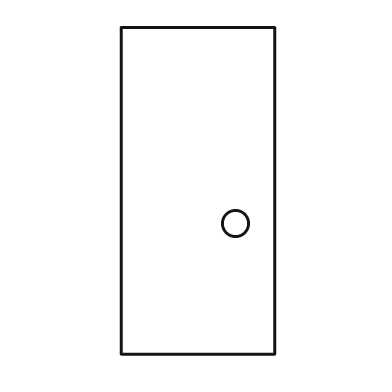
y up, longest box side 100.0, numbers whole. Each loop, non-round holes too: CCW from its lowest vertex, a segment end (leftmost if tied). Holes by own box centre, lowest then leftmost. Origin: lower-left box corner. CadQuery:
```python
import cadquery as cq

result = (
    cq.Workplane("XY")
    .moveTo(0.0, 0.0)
    .lineTo(47.0, 0.0)
    .lineTo(47.0, 100.0)
    .lineTo(0.0, 100.0)
    .close()
    .moveTo(35.0, 40.0)
    .circle(4.0)
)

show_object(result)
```